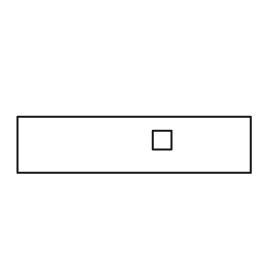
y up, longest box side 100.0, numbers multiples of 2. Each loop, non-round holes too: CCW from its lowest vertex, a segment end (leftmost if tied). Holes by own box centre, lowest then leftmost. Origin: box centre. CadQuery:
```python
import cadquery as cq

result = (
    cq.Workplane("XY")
    .moveTo(-50.0, -12.0)
    .lineTo(50.0, -12.0)
    .lineTo(50.0, 12.0)
    .lineTo(-50.0, 12.0)
    .close()
    .moveTo(8.0, -2.0)
    .lineTo(16.0, -2.0)
    .lineTo(16.0, 6.0)
    .lineTo(8.0, 6.0)
    .close()
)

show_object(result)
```